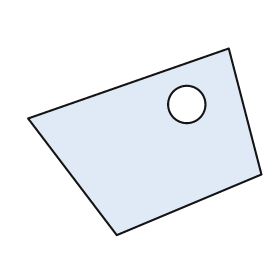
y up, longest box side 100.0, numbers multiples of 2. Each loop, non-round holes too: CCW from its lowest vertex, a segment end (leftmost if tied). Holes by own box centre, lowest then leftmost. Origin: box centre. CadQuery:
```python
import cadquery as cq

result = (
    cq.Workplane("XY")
    .moveTo(-12.0, -40.0)
    .lineTo(50.0, -14.0)
    .lineTo(36.0, 40.0)
    .lineTo(-50.0, 10.0)
    .close()
    .moveTo(18.0, 16.0)
    .circle(8.0)
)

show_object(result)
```